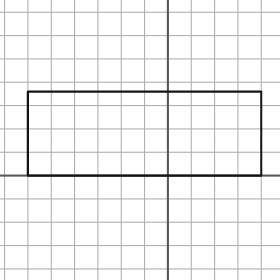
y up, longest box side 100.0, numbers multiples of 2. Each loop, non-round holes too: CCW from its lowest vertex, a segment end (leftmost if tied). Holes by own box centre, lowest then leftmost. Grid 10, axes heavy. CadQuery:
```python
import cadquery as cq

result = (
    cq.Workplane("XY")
    .moveTo(-60.0, 0.0)
    .lineTo(40.0, 0.0)
    .lineTo(40.0, 36.0)
    .lineTo(-60.0, 36.0)
    .close()
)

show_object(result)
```